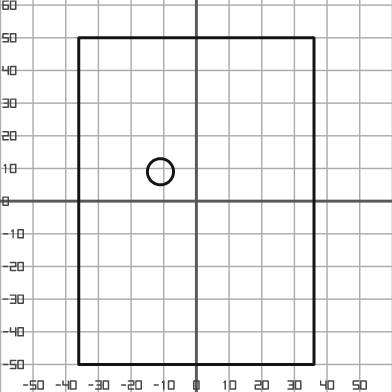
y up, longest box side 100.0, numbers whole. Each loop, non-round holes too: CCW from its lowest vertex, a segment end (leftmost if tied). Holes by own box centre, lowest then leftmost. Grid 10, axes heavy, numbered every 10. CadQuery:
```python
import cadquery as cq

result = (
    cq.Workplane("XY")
    .moveTo(-36.0, -50.0)
    .lineTo(36.0, -50.0)
    .lineTo(36.0, 50.0)
    .lineTo(-36.0, 50.0)
    .close()
    .moveTo(-11.0, 9.0)
    .circle(4.0)
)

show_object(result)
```